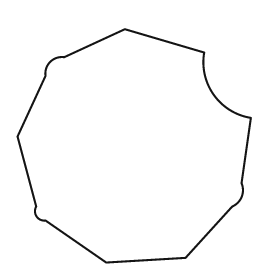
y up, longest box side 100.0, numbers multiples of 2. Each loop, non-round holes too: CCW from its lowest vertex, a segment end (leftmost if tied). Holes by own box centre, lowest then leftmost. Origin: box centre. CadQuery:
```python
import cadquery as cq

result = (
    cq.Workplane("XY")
    .moveTo(-12.0, -50.0)
    .lineTo(22.0, -48.0)
    .lineTo(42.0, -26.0)
    .threePointArc((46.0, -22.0), (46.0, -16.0))
    .lineTo(50.0, 12.0)
    .threePointArc((34.0, 22.0), (30.0, 40.0))
    .lineTo(-4.0, 50.0)
    .lineTo(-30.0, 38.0)
    .threePointArc((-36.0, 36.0), (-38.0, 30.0))
    .lineTo(-50.0, 4.0)
    .lineTo(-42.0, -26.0)
    .threePointArc((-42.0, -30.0), (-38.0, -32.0))
    .close()
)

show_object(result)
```